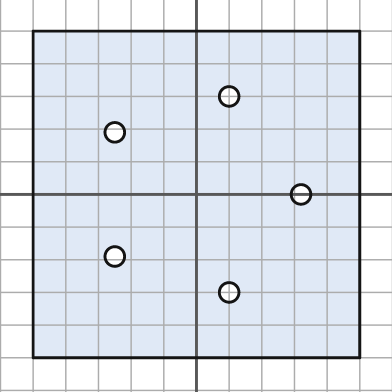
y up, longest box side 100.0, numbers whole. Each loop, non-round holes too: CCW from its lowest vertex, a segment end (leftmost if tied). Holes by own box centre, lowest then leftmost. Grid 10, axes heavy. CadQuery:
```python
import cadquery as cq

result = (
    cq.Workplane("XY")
    .moveTo(-50.0, -50.0)
    .lineTo(50.0, -50.0)
    .lineTo(50.0, 50.0)
    .lineTo(-50.0, 50.0)
    .close()
    .moveTo(10.0, -30.0)
    .circle(3.0)
    .moveTo(-25.0, -19.0)
    .circle(3.0)
    .moveTo(32.0, 0.0)
    .circle(3.0)
    .moveTo(-25.0, 19.0)
    .circle(3.0)
    .moveTo(10.0, 30.0)
    .circle(3.0)
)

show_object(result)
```